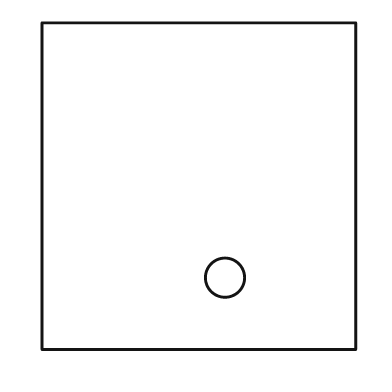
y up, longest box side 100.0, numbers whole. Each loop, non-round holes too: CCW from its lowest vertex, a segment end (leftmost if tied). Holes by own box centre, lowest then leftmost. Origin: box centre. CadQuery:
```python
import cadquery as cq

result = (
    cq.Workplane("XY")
    .moveTo(-48.0, -50.0)
    .lineTo(48.0, -50.0)
    .lineTo(48.0, 50.0)
    .lineTo(-48.0, 50.0)
    .close()
    .moveTo(8.0, -28.0)
    .circle(6.0)
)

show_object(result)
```